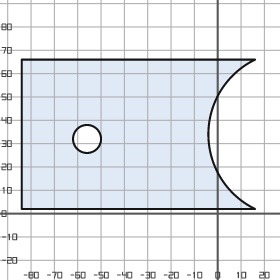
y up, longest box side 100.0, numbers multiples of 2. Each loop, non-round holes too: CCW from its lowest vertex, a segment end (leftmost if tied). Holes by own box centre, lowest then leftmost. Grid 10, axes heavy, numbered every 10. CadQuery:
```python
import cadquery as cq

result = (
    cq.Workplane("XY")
    .moveTo(-84.0, 2.0)
    .lineTo(16.0, 2.0)
    .threePointArc((-4.0, 34.0), (16.0, 66.0))
    .lineTo(-84.0, 66.0)
    .close()
    .moveTo(-56.0, 32.0)
    .circle(6.0)
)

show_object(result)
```